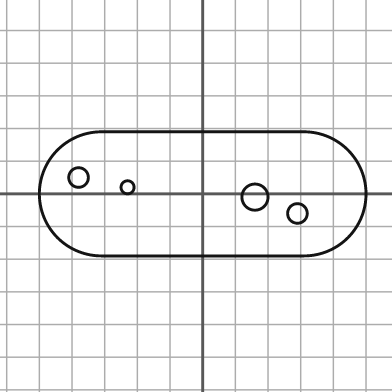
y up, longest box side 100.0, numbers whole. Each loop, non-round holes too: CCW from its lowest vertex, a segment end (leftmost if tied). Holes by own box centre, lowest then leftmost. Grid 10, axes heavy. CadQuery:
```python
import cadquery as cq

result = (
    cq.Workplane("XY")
    .moveTo(-31.0, -19.0)
    .lineTo(31.0, -19.0)
    .threePointArc((50.0, 0.0), (31.0, 19.0))
    .lineTo(-31.0, 19.0)
    .threePointArc((-50.0, 0.0), (-31.0, -19.0))
    .close()
    .moveTo(29.0, -6.0)
    .circle(3.0)
    .moveTo(16.0, -1.0)
    .circle(4.0)
    .moveTo(-23.0, 2.0)
    .circle(2.0)
    .moveTo(-38.0, 5.0)
    .circle(3.0)
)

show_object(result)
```